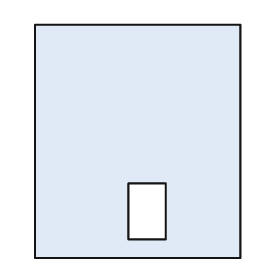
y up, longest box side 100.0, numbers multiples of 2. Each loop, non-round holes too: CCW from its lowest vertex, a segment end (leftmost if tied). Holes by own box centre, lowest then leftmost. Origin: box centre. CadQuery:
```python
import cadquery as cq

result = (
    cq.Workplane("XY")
    .moveTo(-44.0, -50.0)
    .lineTo(44.0, -50.0)
    .lineTo(44.0, 50.0)
    .lineTo(-44.0, 50.0)
    .close()
    .moveTo(-4.0, -42.0)
    .lineTo(12.0, -42.0)
    .lineTo(12.0, -18.0)
    .lineTo(-4.0, -18.0)
    .close()
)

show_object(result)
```